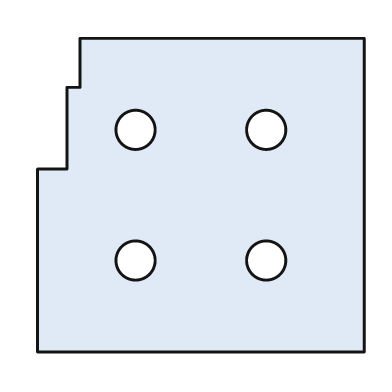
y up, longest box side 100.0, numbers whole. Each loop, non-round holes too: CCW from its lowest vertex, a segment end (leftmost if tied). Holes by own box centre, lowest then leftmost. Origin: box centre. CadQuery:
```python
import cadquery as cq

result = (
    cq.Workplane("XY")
    .moveTo(-50.0, -48.0)
    .lineTo(50.0, -48.0)
    .lineTo(50.0, 48.0)
    .lineTo(-37.0, 48.0)
    .lineTo(-37.0, 33.0)
    .lineTo(-41.0, 33.0)
    .lineTo(-41.0, 8.0)
    .lineTo(-50.0, 8.0)
    .close()
    .moveTo(-20.0, -20.0)
    .circle(6.0)
    .moveTo(20.0, -20.0)
    .circle(6.0)
    .moveTo(-20.0, 20.0)
    .circle(6.0)
    .moveTo(20.0, 20.0)
    .circle(6.0)
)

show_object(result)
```